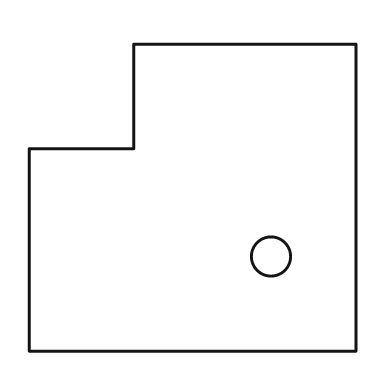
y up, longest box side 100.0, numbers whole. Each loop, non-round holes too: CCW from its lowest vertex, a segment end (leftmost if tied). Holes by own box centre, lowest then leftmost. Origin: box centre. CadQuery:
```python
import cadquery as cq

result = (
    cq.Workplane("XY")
    .moveTo(-50.0, -47.0)
    .lineTo(50.0, -47.0)
    .lineTo(50.0, 47.0)
    .lineTo(-18.0, 47.0)
    .lineTo(-18.0, 15.0)
    .lineTo(-50.0, 15.0)
    .close()
    .moveTo(24.0, -18.0)
    .circle(6.0)
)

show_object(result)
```